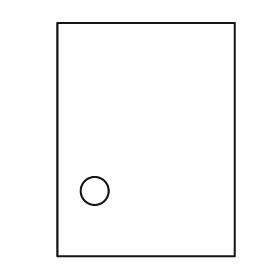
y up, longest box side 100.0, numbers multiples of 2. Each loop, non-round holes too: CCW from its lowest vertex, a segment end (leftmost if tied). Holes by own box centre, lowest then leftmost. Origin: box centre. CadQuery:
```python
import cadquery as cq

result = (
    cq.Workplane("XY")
    .moveTo(-38.0, -50.0)
    .lineTo(38.0, -50.0)
    .lineTo(38.0, 50.0)
    .lineTo(-38.0, 50.0)
    .close()
    .moveTo(-22.0, -22.0)
    .circle(6.0)
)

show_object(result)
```